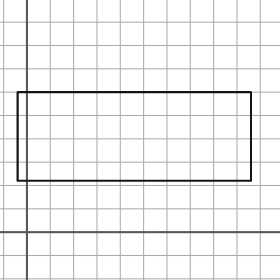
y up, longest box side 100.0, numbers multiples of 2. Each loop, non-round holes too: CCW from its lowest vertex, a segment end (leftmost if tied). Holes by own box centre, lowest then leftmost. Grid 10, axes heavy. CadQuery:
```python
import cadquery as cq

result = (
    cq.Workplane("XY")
    .moveTo(-4.0, 22.0)
    .lineTo(96.0, 22.0)
    .lineTo(96.0, 60.0)
    .lineTo(-4.0, 60.0)
    .close()
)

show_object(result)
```